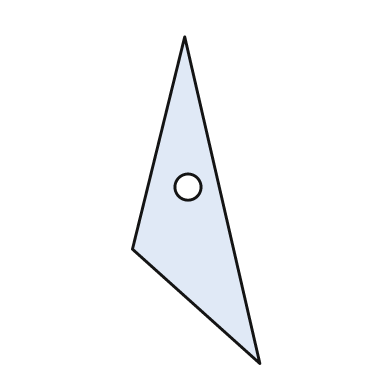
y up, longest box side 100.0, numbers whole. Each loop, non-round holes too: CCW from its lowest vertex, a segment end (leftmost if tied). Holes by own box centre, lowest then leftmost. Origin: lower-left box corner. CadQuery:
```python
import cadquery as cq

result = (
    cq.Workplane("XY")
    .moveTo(39.0, 0.0)
    .lineTo(16.0, 100.0)
    .lineTo(0.0, 35.0)
    .close()
    .moveTo(17.0, 54.0)
    .circle(4.0)
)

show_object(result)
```